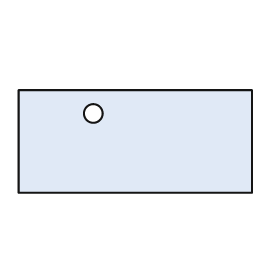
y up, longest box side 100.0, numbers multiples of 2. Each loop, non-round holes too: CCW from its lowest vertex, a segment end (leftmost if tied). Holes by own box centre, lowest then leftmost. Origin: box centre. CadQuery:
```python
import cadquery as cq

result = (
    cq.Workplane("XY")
    .moveTo(-50.0, -22.0)
    .lineTo(50.0, -22.0)
    .lineTo(50.0, 22.0)
    .lineTo(-50.0, 22.0)
    .close()
    .moveTo(-18.0, 12.0)
    .circle(4.0)
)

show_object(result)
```